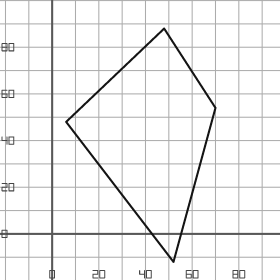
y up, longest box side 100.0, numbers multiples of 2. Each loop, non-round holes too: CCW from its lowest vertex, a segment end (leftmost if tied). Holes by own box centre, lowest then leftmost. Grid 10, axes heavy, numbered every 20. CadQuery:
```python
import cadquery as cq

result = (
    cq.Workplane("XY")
    .moveTo(52.0, -12.0)
    .lineTo(70.0, 54.0)
    .lineTo(48.0, 88.0)
    .lineTo(6.0, 48.0)
    .close()
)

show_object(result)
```